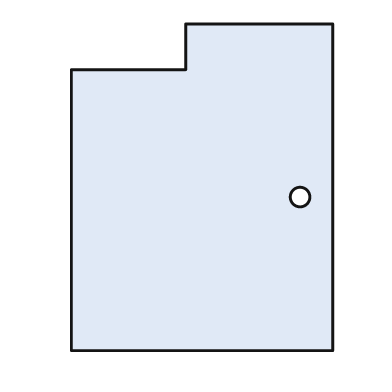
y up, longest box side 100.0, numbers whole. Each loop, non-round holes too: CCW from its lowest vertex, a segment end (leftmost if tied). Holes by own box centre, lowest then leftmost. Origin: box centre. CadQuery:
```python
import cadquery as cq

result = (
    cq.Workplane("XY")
    .moveTo(-40.0, -50.0)
    .lineTo(40.0, -50.0)
    .lineTo(40.0, 50.0)
    .lineTo(-5.0, 50.0)
    .lineTo(-5.0, 36.0)
    .lineTo(-40.0, 36.0)
    .close()
    .moveTo(30.0, -3.0)
    .circle(3.0)
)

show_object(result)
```